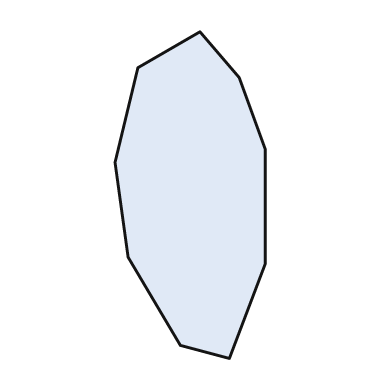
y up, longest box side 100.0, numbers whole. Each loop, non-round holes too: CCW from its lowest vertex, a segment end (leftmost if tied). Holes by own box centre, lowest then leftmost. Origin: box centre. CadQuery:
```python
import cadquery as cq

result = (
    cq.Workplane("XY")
    .moveTo(12.0, -50.0)
    .lineTo(23.0, -21.0)
    .lineTo(23.0, 14.0)
    .lineTo(15.0, 36.0)
    .lineTo(3.0, 50.0)
    .lineTo(-16.0, 39.0)
    .lineTo(-23.0, 10.0)
    .lineTo(-19.0, -19.0)
    .lineTo(-3.0, -46.0)
    .close()
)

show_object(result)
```